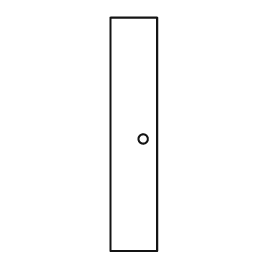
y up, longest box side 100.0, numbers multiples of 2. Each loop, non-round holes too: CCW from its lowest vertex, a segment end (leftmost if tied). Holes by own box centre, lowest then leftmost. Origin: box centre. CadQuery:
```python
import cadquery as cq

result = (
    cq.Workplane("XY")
    .moveTo(-10.0, -50.0)
    .lineTo(10.0, -50.0)
    .lineTo(10.0, 50.0)
    .lineTo(-10.0, 50.0)
    .close()
    .moveTo(4.0, -2.0)
    .circle(2.0)
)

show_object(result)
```